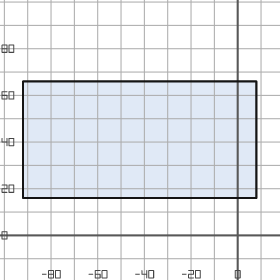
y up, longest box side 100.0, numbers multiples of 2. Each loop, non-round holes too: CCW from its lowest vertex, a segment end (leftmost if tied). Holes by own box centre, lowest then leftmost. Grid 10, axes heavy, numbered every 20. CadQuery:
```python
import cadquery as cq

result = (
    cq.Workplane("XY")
    .moveTo(-92.0, 16.0)
    .lineTo(8.0, 16.0)
    .lineTo(8.0, 66.0)
    .lineTo(-92.0, 66.0)
    .close()
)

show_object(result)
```